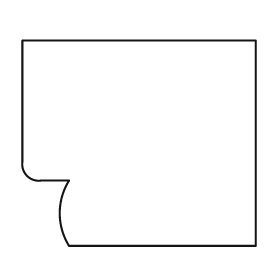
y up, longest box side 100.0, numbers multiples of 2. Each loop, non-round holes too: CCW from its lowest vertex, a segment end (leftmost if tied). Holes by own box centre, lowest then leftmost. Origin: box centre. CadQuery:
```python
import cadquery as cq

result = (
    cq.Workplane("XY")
    .moveTo(-30.0, -44.0)
    .lineTo(50.0, -44.0)
    .lineTo(50.0, 44.0)
    .lineTo(-50.0, 44.0)
    .lineTo(-50.0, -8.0)
    .threePointArc((-48.0, -14.0), (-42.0, -16.0))
    .lineTo(-30.0, -16.0)
    .threePointArc((-34.0, -30.0), (-30.0, -44.0))
    .close()
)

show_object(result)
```